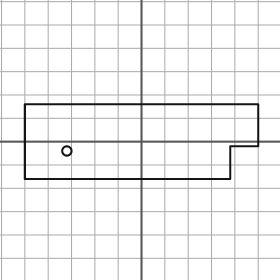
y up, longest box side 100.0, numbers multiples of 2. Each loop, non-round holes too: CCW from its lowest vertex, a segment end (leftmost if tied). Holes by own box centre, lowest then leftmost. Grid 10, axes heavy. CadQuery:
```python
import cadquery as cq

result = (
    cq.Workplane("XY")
    .moveTo(-50.0, -16.0)
    .lineTo(38.0, -16.0)
    .lineTo(38.0, -2.0)
    .lineTo(50.0, -2.0)
    .lineTo(50.0, 16.0)
    .lineTo(-50.0, 16.0)
    .close()
    .moveTo(-32.0, -4.0)
    .circle(2.0)
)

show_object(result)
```